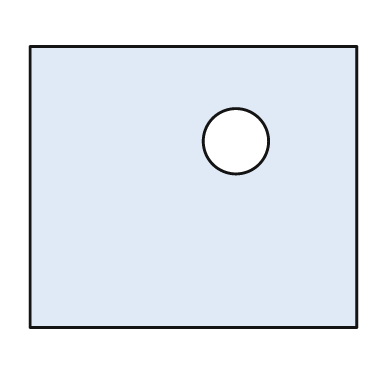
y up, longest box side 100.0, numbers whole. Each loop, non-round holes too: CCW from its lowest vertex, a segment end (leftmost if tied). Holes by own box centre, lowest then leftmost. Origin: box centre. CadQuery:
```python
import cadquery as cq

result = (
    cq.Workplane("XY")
    .moveTo(-50.0, -43.0)
    .lineTo(50.0, -43.0)
    .lineTo(50.0, 43.0)
    .lineTo(-50.0, 43.0)
    .close()
    .moveTo(13.0, 14.0)
    .circle(10.0)
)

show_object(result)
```